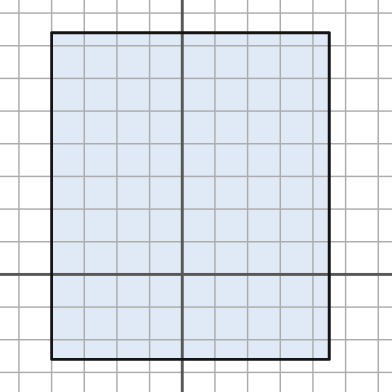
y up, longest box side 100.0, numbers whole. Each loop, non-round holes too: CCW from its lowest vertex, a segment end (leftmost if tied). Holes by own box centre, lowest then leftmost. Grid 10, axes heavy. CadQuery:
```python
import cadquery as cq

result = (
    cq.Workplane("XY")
    .moveTo(-40.0, -26.0)
    .lineTo(45.0, -26.0)
    .lineTo(45.0, 74.0)
    .lineTo(-40.0, 74.0)
    .close()
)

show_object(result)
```